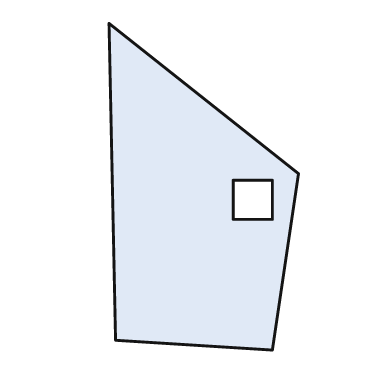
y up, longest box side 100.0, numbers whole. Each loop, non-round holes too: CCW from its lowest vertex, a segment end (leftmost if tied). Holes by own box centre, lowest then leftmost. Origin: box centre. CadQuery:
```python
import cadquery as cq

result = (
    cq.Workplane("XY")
    .moveTo(21.0, -50.0)
    .lineTo(29.0, 4.0)
    .lineTo(-29.0, 50.0)
    .lineTo(-27.0, -47.0)
    .close()
    .moveTo(9.0, -10.0)
    .lineTo(21.0, -10.0)
    .lineTo(21.0, 2.0)
    .lineTo(9.0, 2.0)
    .close()
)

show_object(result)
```